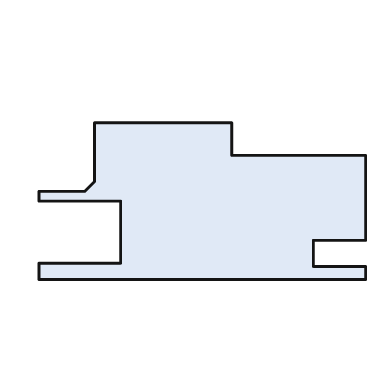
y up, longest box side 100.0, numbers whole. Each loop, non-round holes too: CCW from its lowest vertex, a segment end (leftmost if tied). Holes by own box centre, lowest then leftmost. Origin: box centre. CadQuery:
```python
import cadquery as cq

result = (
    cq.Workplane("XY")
    .moveTo(-50.0, -24.0)
    .lineTo(50.0, -24.0)
    .lineTo(50.0, -20.0)
    .lineTo(34.0, -20.0)
    .lineTo(34.0, -12.0)
    .lineTo(50.0, -12.0)
    .lineTo(50.0, 14.0)
    .lineTo(9.0, 14.0)
    .lineTo(9.0, 24.0)
    .lineTo(-33.0, 24.0)
    .lineTo(-33.0, 6.0)
    .lineTo(-36.0, 3.0)
    .lineTo(-50.0, 3.0)
    .lineTo(-50.0, 0.0)
    .lineTo(-25.0, 0.0)
    .lineTo(-25.0, -19.0)
    .lineTo(-50.0, -19.0)
    .close()
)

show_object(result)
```